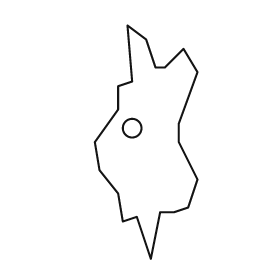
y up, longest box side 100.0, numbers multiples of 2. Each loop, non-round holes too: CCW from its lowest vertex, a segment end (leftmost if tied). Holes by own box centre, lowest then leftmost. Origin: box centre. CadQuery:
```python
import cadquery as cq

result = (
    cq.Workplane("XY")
    .moveTo(2.0, -50.0)
    .lineTo(6.0, -30.0)
    .lineTo(12.0, -30.0)
    .lineTo(18.0, -28.0)
    .lineTo(22.0, -16.0)
    .lineTo(14.0, 0.0)
    .lineTo(14.0, 8.0)
    .lineTo(22.0, 30.0)
    .lineTo(16.0, 40.0)
    .lineTo(8.0, 32.0)
    .lineTo(4.0, 32.0)
    .lineTo(0.0, 44.0)
    .lineTo(-8.0, 50.0)
    .lineTo(-6.0, 26.0)
    .lineTo(-12.0, 24.0)
    .lineTo(-12.0, 14.0)
    .lineTo(-22.0, 0.0)
    .lineTo(-20.0, -12.0)
    .lineTo(-12.0, -22.0)
    .lineTo(-10.0, -34.0)
    .lineTo(-4.0, -32.0)
    .close()
    .moveTo(-6.0, 6.0)
    .circle(4.0)
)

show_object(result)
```